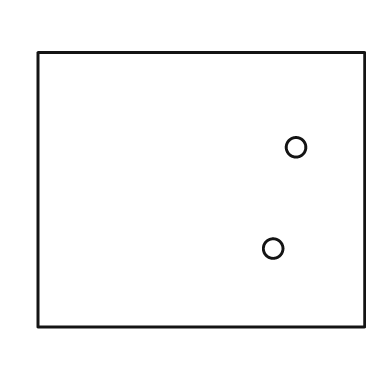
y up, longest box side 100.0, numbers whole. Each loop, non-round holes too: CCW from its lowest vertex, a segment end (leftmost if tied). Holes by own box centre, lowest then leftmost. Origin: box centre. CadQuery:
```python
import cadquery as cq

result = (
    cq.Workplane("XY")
    .moveTo(-50.0, -42.0)
    .lineTo(50.0, -42.0)
    .lineTo(50.0, 42.0)
    .lineTo(-50.0, 42.0)
    .close()
    .moveTo(22.0, -18.0)
    .circle(3.0)
    .moveTo(29.0, 13.0)
    .circle(3.0)
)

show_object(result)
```